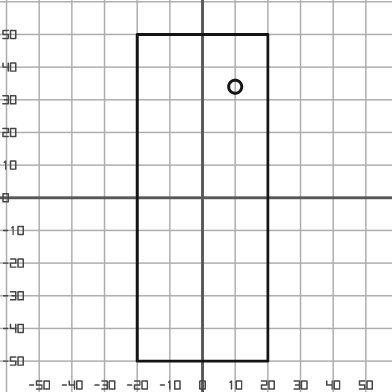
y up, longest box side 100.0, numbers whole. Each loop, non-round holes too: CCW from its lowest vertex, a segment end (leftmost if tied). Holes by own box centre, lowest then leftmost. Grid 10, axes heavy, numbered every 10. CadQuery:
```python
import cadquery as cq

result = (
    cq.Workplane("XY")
    .moveTo(-20.0, -50.0)
    .lineTo(20.0, -50.0)
    .lineTo(20.0, 50.0)
    .lineTo(-20.0, 50.0)
    .close()
    .moveTo(10.0, 34.0)
    .circle(2.0)
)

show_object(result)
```